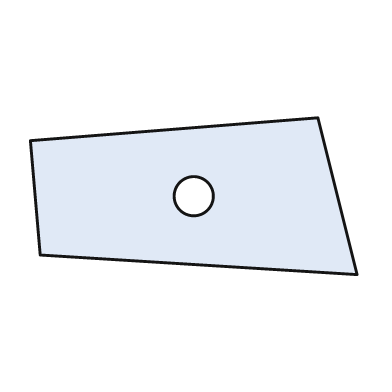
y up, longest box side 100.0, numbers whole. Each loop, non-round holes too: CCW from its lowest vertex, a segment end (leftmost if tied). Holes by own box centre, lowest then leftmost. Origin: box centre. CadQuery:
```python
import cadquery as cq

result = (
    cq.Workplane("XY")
    .moveTo(50.0, -24.0)
    .lineTo(38.0, 24.0)
    .lineTo(-50.0, 17.0)
    .lineTo(-47.0, -18.0)
    .close()
    .moveTo(0.0, 0.0)
    .circle(6.0)
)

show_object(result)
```